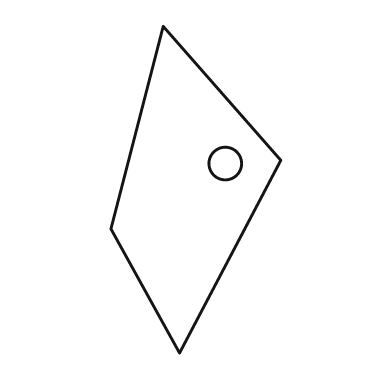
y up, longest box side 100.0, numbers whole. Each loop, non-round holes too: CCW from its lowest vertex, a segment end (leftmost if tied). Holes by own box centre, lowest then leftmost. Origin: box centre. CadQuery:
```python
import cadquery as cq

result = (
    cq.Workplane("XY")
    .moveTo(-5.0, -50.0)
    .lineTo(26.0, 9.0)
    .lineTo(-10.0, 50.0)
    .lineTo(-26.0, -12.0)
    .close()
    .moveTo(9.0, 8.0)
    .circle(5.0)
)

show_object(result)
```